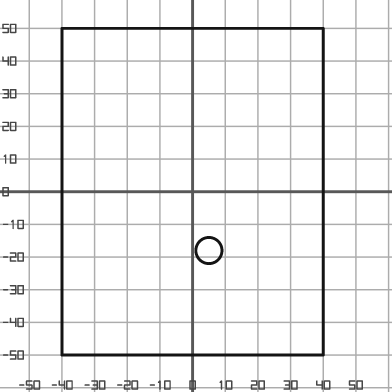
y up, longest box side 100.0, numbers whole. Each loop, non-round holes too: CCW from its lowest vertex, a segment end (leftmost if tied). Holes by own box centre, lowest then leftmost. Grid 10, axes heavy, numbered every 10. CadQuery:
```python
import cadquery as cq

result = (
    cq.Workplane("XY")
    .moveTo(-40.0, -50.0)
    .lineTo(40.0, -50.0)
    .lineTo(40.0, 50.0)
    .lineTo(-40.0, 50.0)
    .close()
    .moveTo(5.0, -18.0)
    .circle(4.0)
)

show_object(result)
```